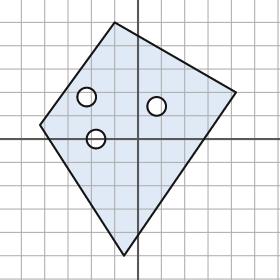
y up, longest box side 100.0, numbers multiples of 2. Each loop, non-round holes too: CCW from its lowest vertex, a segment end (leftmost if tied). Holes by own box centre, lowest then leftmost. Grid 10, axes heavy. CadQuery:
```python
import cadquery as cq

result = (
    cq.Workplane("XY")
    .moveTo(-6.0, -50.0)
    .lineTo(42.0, 20.0)
    .lineTo(-10.0, 50.0)
    .lineTo(-42.0, 6.0)
    .close()
    .moveTo(-18.0, 0.0)
    .circle(4.0)
    .moveTo(8.0, 14.0)
    .circle(4.0)
    .moveTo(-22.0, 18.0)
    .circle(4.0)
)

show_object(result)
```